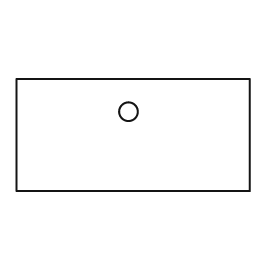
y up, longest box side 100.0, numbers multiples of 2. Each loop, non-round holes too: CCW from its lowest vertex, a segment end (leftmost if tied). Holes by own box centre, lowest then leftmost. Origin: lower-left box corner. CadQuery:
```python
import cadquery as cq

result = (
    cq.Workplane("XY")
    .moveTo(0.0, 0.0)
    .lineTo(100.0, 0.0)
    .lineTo(100.0, 48.0)
    .lineTo(0.0, 48.0)
    .close()
    .moveTo(48.0, 34.0)
    .circle(4.0)
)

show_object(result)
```